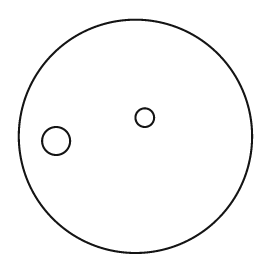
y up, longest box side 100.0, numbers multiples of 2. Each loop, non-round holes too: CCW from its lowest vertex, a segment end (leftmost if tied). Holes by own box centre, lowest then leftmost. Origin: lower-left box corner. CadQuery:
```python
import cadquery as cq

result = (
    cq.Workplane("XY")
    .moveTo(50.0, 50.0)
    .circle(50.0)
    .moveTo(16.0, 48.0)
    .circle(6.0)
    .moveTo(54.0, 58.0)
    .circle(4.0)
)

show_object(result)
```